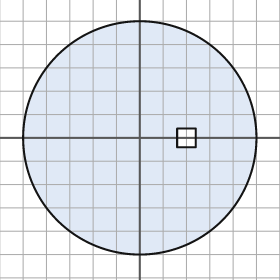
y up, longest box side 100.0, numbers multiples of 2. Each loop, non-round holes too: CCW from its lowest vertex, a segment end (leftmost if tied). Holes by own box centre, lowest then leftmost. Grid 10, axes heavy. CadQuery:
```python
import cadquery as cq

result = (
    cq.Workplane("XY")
    .moveTo(0.0, 0.0)
    .circle(50.0)
    .moveTo(16.0, -4.0)
    .lineTo(24.0, -4.0)
    .lineTo(24.0, 4.0)
    .lineTo(16.0, 4.0)
    .close()
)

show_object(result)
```